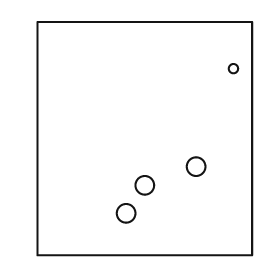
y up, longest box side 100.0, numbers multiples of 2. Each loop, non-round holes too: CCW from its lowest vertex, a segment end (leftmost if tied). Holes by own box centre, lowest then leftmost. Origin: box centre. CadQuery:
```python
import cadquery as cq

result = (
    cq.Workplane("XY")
    .moveTo(-46.0, -50.0)
    .lineTo(46.0, -50.0)
    .lineTo(46.0, 50.0)
    .lineTo(-46.0, 50.0)
    .close()
    .moveTo(-8.0, -32.0)
    .circle(4.0)
    .moveTo(0.0, -20.0)
    .circle(4.0)
    .moveTo(22.0, -12.0)
    .circle(4.0)
    .moveTo(38.0, 30.0)
    .circle(2.0)
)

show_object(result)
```